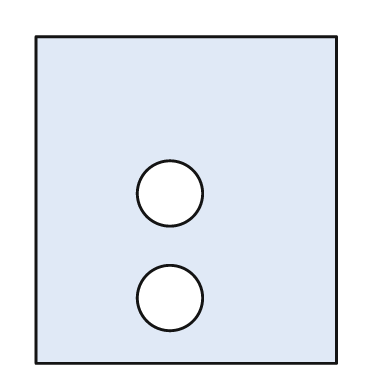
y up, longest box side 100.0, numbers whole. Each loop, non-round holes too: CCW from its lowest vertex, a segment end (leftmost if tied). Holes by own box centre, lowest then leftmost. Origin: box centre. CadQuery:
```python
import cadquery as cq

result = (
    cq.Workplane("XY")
    .moveTo(-46.0, -50.0)
    .lineTo(46.0, -50.0)
    .lineTo(46.0, 50.0)
    .lineTo(-46.0, 50.0)
    .close()
    .moveTo(-5.0, -30.0)
    .circle(10.0)
    .moveTo(-5.0, 2.0)
    .circle(10.0)
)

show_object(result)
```